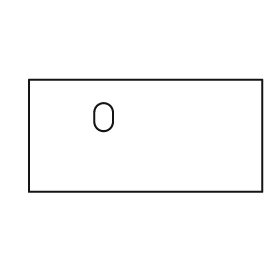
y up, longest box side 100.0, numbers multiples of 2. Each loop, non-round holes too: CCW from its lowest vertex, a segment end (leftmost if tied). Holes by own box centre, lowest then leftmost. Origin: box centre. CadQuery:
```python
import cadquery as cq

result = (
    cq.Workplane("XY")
    .moveTo(-50.0, -24.0)
    .lineTo(50.0, -24.0)
    .lineTo(50.0, 24.0)
    .lineTo(-50.0, 24.0)
    .close()
    .moveTo(-22.0, 6.0)
    .threePointArc((-18.0, 2.0), (-14.0, 6.0))
    .lineTo(-14.0, 10.0)
    .threePointArc((-18.0, 14.0), (-22.0, 10.0))
    .close()
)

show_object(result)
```